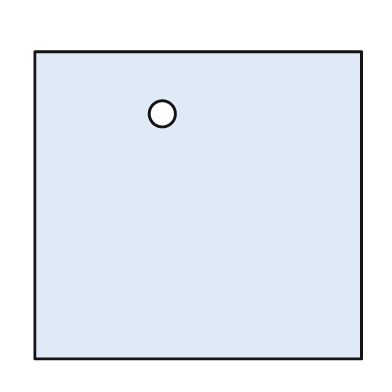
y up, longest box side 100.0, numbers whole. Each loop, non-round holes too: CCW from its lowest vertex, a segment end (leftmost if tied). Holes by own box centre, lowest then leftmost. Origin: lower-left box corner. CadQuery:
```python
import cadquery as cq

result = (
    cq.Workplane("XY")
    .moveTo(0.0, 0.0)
    .lineTo(100.0, 0.0)
    .lineTo(100.0, 94.0)
    .lineTo(0.0, 94.0)
    .close()
    .moveTo(39.0, 75.0)
    .circle(4.0)
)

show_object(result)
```